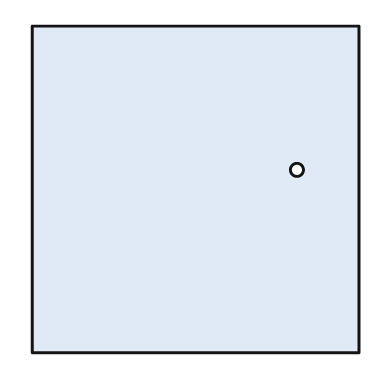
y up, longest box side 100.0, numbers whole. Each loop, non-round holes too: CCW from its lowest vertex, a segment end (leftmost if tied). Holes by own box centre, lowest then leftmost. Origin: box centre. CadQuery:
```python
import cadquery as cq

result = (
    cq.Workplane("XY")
    .moveTo(-50.0, -50.0)
    .lineTo(50.0, -50.0)
    .lineTo(50.0, 50.0)
    .lineTo(-50.0, 50.0)
    .close()
    .moveTo(31.0, 6.0)
    .circle(2.0)
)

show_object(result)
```